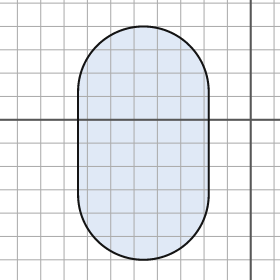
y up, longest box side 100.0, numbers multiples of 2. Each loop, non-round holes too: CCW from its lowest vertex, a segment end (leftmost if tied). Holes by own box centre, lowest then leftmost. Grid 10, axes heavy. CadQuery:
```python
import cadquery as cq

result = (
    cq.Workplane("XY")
    .moveTo(-74.0, -32.0)
    .threePointArc((-46.0, -60.0), (-18.0, -32.0))
    .lineTo(-18.0, 12.0)
    .threePointArc((-46.0, 40.0), (-74.0, 12.0))
    .close()
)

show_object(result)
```